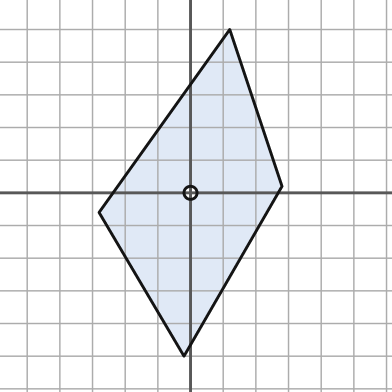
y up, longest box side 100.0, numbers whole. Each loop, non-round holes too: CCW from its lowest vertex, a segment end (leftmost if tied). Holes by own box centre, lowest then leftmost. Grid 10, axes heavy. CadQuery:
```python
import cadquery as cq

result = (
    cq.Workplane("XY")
    .moveTo(-2.0, -50.0)
    .lineTo(28.0, 2.0)
    .lineTo(12.0, 50.0)
    .lineTo(-28.0, -6.0)
    .close()
    .moveTo(0.0, 0.0)
    .circle(2.0)
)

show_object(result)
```